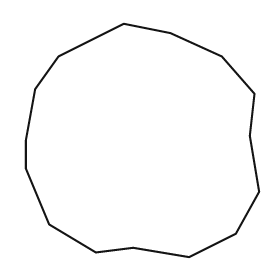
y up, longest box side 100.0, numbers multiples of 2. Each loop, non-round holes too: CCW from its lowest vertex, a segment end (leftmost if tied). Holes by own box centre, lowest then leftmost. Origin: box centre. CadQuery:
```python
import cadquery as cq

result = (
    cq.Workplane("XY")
    .moveTo(20.0, -50.0)
    .lineTo(40.0, -40.0)
    .lineTo(50.0, -22.0)
    .lineTo(46.0, 2.0)
    .lineTo(48.0, 20.0)
    .lineTo(34.0, 36.0)
    .lineTo(12.0, 46.0)
    .lineTo(-8.0, 50.0)
    .lineTo(-36.0, 36.0)
    .lineTo(-46.0, 22.0)
    .lineTo(-50.0, 0.0)
    .lineTo(-50.0, -12.0)
    .lineTo(-40.0, -36.0)
    .lineTo(-20.0, -48.0)
    .lineTo(-4.0, -46.0)
    .close()
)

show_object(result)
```